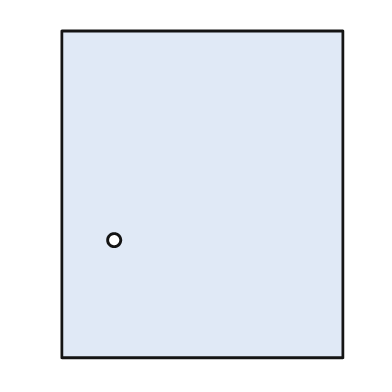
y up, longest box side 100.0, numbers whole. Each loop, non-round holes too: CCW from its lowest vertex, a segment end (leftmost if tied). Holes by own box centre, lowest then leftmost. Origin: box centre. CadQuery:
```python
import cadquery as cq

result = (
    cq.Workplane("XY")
    .moveTo(-43.0, -50.0)
    .lineTo(43.0, -50.0)
    .lineTo(43.0, 50.0)
    .lineTo(-43.0, 50.0)
    .close()
    .moveTo(-27.0, -14.0)
    .circle(2.0)
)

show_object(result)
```